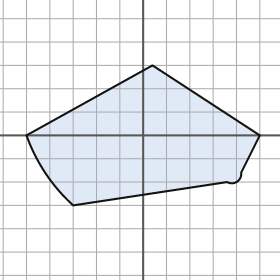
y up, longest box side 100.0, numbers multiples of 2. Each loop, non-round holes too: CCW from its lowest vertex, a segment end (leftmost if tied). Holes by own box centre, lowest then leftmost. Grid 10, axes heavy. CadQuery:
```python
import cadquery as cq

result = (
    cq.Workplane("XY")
    .moveTo(-30.0, -30.0)
    .lineTo(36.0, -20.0)
    .threePointArc((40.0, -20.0), (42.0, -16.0))
    .lineTo(50.0, 0.0)
    .lineTo(4.0, 30.0)
    .lineTo(-50.0, 0.0)
    .threePointArc((-42.0, -16.0), (-30.0, -30.0))
    .close()
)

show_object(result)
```